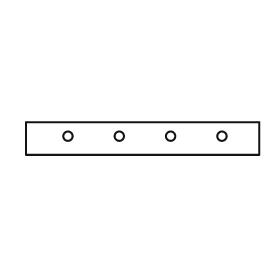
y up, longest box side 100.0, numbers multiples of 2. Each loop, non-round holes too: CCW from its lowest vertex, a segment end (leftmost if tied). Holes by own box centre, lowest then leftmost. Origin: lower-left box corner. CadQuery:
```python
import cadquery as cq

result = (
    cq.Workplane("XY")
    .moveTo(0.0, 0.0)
    .lineTo(100.0, 0.0)
    .lineTo(100.0, 14.0)
    .lineTo(0.0, 14.0)
    .close()
    .moveTo(18.0, 8.0)
    .circle(2.0)
    .moveTo(40.0, 8.0)
    .circle(2.0)
    .moveTo(62.0, 8.0)
    .circle(2.0)
    .moveTo(84.0, 8.0)
    .circle(2.0)
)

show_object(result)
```